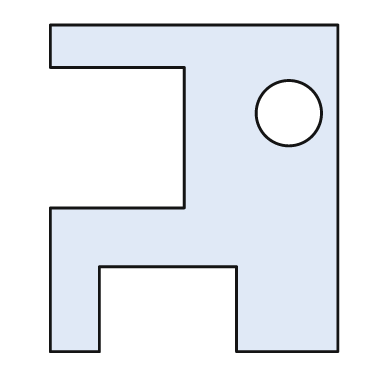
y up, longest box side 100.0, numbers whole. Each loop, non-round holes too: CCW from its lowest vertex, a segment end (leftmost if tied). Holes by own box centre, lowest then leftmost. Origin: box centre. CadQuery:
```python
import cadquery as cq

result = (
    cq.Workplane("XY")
    .moveTo(-44.0, -50.0)
    .lineTo(-29.0, -50.0)
    .lineTo(-29.0, -24.0)
    .lineTo(13.0, -24.0)
    .lineTo(13.0, -50.0)
    .lineTo(44.0, -50.0)
    .lineTo(44.0, 50.0)
    .lineTo(-44.0, 50.0)
    .lineTo(-44.0, 37.0)
    .lineTo(-3.0, 37.0)
    .lineTo(-3.0, -6.0)
    .lineTo(-44.0, -6.0)
    .close()
    .moveTo(29.0, 23.0)
    .circle(10.0)
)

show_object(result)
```